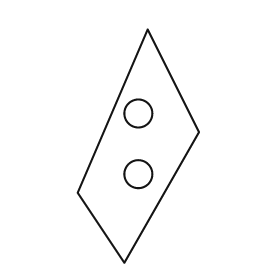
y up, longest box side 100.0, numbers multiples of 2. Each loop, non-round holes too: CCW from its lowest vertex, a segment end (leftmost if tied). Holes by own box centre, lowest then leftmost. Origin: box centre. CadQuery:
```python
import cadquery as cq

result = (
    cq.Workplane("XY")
    .moveTo(-6.0, -50.0)
    .lineTo(26.0, 6.0)
    .lineTo(4.0, 50.0)
    .lineTo(-26.0, -20.0)
    .close()
    .moveTo(0.0, -12.0)
    .circle(6.0)
    .moveTo(0.0, 14.0)
    .circle(6.0)
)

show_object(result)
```